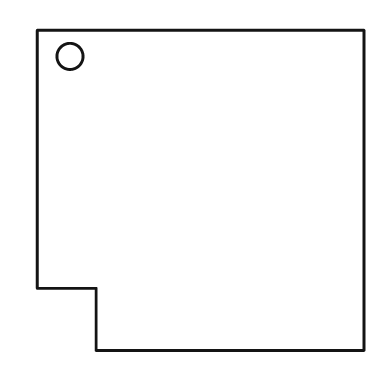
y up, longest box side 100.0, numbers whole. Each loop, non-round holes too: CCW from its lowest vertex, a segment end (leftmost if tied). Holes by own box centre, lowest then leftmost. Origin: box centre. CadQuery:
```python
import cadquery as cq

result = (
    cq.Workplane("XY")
    .moveTo(-32.0, -49.0)
    .lineTo(50.0, -49.0)
    .lineTo(50.0, 49.0)
    .lineTo(-50.0, 49.0)
    .lineTo(-50.0, -30.0)
    .lineTo(-32.0, -30.0)
    .close()
    .moveTo(-40.0, 41.0)
    .circle(4.0)
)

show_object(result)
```